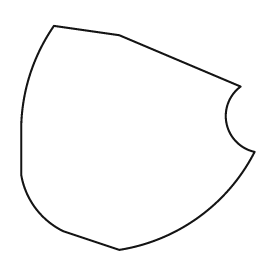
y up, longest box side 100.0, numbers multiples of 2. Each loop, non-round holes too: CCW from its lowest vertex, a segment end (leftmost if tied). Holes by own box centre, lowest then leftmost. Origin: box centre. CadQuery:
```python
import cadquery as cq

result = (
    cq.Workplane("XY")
    .moveTo(-8.0, -48.0)
    .threePointArc((26.0, -34.0), (50.0, -6.0))
    .threePointArc((38.0, 6.0), (44.0, 22.0))
    .lineTo(-8.0, 44.0)
    .lineTo(-36.0, 48.0)
    .threePointArc((-46.0, 28.0), (-50.0, 6.0))
    .lineTo(-50.0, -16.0)
    .threePointArc((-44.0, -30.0), (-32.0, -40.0))
    .close()
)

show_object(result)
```